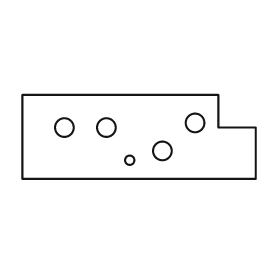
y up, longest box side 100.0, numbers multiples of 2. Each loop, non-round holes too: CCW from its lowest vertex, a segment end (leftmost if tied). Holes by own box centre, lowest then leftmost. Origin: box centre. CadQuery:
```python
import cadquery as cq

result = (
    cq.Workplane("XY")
    .moveTo(-50.0, -18.0)
    .lineTo(50.0, -18.0)
    .lineTo(50.0, 4.0)
    .lineTo(34.0, 4.0)
    .lineTo(34.0, 18.0)
    .lineTo(-50.0, 18.0)
    .close()
    .moveTo(-4.0, -10.0)
    .circle(2.0)
    .moveTo(10.0, -6.0)
    .circle(4.0)
    .moveTo(-32.0, 4.0)
    .circle(4.0)
    .moveTo(-14.0, 4.0)
    .circle(4.0)
    .moveTo(24.0, 6.0)
    .circle(4.0)
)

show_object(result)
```